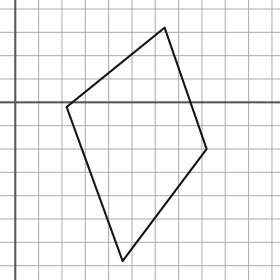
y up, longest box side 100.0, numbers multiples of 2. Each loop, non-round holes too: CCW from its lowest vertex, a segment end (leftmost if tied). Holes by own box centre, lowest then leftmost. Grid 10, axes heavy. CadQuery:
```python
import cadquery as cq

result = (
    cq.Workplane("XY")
    .moveTo(46.0, -68.0)
    .lineTo(82.0, -20.0)
    .lineTo(64.0, 32.0)
    .lineTo(22.0, -2.0)
    .close()
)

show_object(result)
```